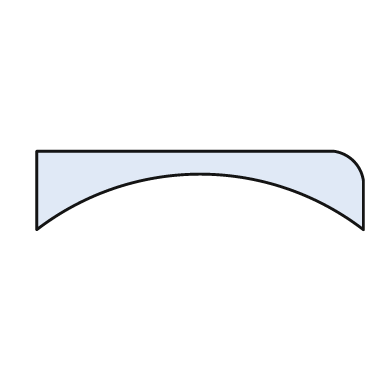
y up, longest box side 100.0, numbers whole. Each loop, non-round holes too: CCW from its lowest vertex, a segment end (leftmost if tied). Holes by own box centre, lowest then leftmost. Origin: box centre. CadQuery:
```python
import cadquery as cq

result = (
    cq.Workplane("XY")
    .moveTo(-50.0, -12.0)
    .threePointArc((0.0, 5.0), (50.0, -12.0))
    .lineTo(50.0, 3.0)
    .threePointArc((47.0, 9.0), (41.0, 12.0))
    .lineTo(-50.0, 12.0)
    .close()
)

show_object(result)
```